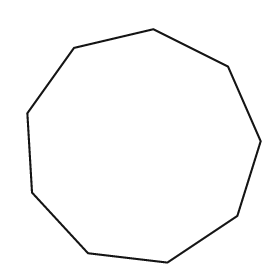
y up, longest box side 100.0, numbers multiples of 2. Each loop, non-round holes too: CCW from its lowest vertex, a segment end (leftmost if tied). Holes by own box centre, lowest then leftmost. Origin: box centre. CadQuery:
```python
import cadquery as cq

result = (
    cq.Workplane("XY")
    .moveTo(10.0, -50.0)
    .lineTo(40.0, -30.0)
    .lineTo(50.0, 2.0)
    .lineTo(36.0, 34.0)
    .lineTo(4.0, 50.0)
    .lineTo(-30.0, 42.0)
    .lineTo(-50.0, 14.0)
    .lineTo(-48.0, -20.0)
    .lineTo(-24.0, -46.0)
    .close()
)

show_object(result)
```